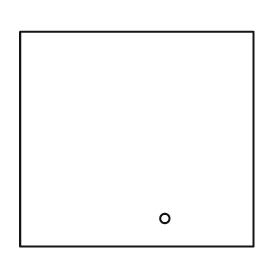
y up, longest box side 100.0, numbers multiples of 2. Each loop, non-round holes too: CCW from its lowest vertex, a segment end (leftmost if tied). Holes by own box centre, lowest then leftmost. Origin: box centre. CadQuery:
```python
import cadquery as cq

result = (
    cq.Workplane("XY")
    .moveTo(-50.0, -46.0)
    .lineTo(50.0, -46.0)
    .lineTo(50.0, 46.0)
    .lineTo(-50.0, 46.0)
    .close()
    .moveTo(12.0, -34.0)
    .circle(2.0)
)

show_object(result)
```